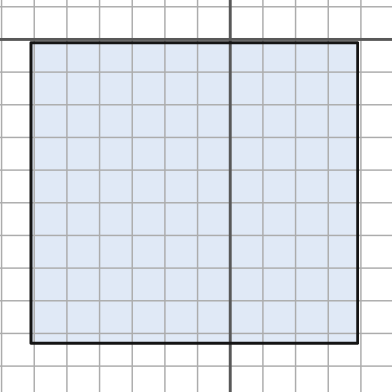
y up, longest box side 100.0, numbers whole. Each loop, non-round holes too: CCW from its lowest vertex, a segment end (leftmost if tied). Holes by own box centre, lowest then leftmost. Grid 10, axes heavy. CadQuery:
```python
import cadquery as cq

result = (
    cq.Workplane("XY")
    .moveTo(-61.0, -93.0)
    .lineTo(39.0, -93.0)
    .lineTo(39.0, -1.0)
    .lineTo(-61.0, -1.0)
    .close()
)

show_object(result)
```